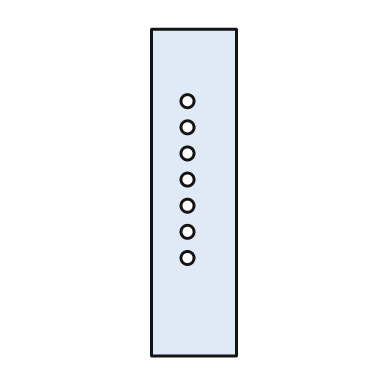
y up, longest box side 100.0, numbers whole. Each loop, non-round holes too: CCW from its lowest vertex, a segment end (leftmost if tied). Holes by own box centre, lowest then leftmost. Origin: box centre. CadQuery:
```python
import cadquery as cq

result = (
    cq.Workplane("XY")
    .moveTo(-13.0, -50.0)
    .lineTo(13.0, -50.0)
    .lineTo(13.0, 50.0)
    .lineTo(-13.0, 50.0)
    .close()
    .moveTo(-2.0, -20.0)
    .circle(2.0)
    .moveTo(-2.0, -12.0)
    .circle(2.0)
    .moveTo(-2.0, -4.0)
    .circle(2.0)
    .moveTo(-2.0, 4.0)
    .circle(2.0)
    .moveTo(-2.0, 12.0)
    .circle(2.0)
    .moveTo(-2.0, 20.0)
    .circle(2.0)
    .moveTo(-2.0, 28.0)
    .circle(2.0)
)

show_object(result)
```